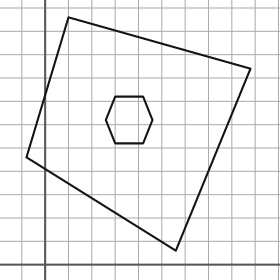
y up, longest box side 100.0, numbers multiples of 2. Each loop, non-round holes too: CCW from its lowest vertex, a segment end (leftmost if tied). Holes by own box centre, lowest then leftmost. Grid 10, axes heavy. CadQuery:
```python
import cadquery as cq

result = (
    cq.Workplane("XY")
    .moveTo(56.0, 6.0)
    .lineTo(88.0, 84.0)
    .lineTo(10.0, 106.0)
    .lineTo(-8.0, 46.0)
    .close()
    .moveTo(30.0, 52.0)
    .lineTo(42.0, 52.0)
    .lineTo(46.0, 62.0)
    .lineTo(42.0, 72.0)
    .lineTo(30.0, 72.0)
    .lineTo(26.0, 62.0)
    .close()
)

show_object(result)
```